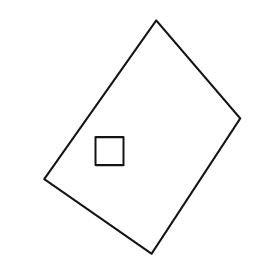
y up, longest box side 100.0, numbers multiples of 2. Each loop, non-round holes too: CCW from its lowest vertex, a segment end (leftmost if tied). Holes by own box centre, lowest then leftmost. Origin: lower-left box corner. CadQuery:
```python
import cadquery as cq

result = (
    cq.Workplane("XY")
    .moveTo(46.0, 0.0)
    .lineTo(84.0, 58.0)
    .lineTo(48.0, 100.0)
    .lineTo(0.0, 32.0)
    .close()
    .moveTo(22.0, 38.0)
    .lineTo(34.0, 38.0)
    .lineTo(34.0, 50.0)
    .lineTo(22.0, 50.0)
    .close()
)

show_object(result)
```